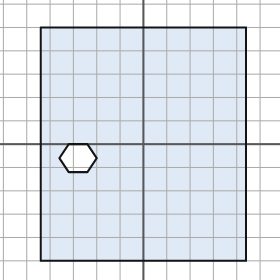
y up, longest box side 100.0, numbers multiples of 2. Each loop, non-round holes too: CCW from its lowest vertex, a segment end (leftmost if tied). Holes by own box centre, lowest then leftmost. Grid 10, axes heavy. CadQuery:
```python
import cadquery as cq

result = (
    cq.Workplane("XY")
    .moveTo(-44.0, -50.0)
    .lineTo(44.0, -50.0)
    .lineTo(44.0, 50.0)
    .lineTo(-44.0, 50.0)
    .close()
    .moveTo(-32.0, -12.0)
    .lineTo(-24.0, -12.0)
    .lineTo(-20.0, -6.0)
    .lineTo(-24.0, 0.0)
    .lineTo(-32.0, 0.0)
    .lineTo(-36.0, -6.0)
    .close()
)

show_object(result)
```